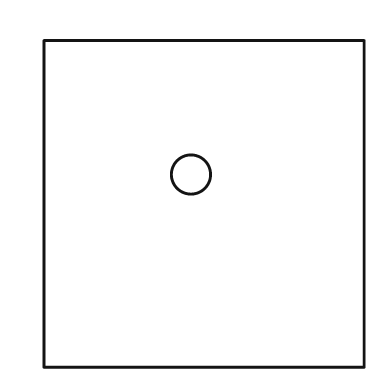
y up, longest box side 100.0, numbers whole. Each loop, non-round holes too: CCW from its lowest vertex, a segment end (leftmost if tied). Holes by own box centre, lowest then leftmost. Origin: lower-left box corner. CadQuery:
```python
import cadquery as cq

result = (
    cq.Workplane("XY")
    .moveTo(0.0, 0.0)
    .lineTo(98.0, 0.0)
    .lineTo(98.0, 100.0)
    .lineTo(0.0, 100.0)
    .close()
    .moveTo(45.0, 59.0)
    .circle(6.0)
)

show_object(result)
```